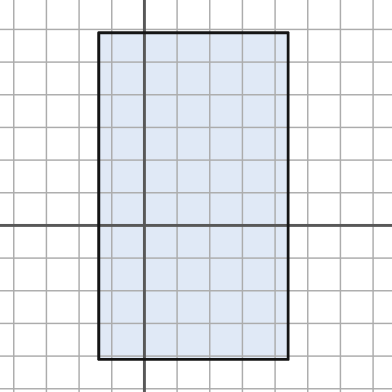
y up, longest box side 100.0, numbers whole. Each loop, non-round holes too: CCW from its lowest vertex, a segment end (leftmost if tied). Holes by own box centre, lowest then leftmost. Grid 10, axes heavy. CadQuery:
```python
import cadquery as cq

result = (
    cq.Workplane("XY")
    .moveTo(-14.0, -41.0)
    .lineTo(44.0, -41.0)
    .lineTo(44.0, 59.0)
    .lineTo(-14.0, 59.0)
    .close()
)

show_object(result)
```